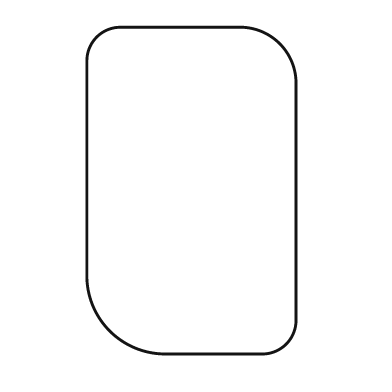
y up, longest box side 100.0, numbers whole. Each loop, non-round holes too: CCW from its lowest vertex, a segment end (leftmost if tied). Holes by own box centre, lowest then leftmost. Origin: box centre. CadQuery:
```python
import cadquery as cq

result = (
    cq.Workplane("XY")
    .moveTo(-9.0, -50.0)
    .lineTo(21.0, -50.0)
    .threePointArc((29.0, -47.0), (32.0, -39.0))
    .lineTo(32.0, 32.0)
    .threePointArc((27.0, 45.0), (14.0, 50.0))
    .lineTo(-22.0, 50.0)
    .threePointArc((-29.0, 47.0), (-32.0, 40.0))
    .lineTo(-32.0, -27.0)
    .threePointArc((-25.0, -43.0), (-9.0, -50.0))
    .close()
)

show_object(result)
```